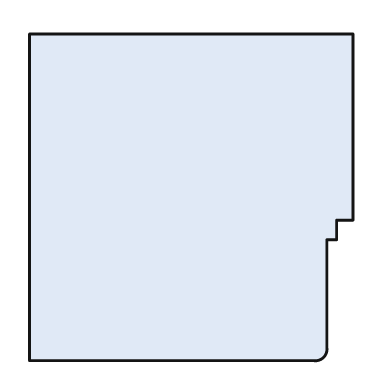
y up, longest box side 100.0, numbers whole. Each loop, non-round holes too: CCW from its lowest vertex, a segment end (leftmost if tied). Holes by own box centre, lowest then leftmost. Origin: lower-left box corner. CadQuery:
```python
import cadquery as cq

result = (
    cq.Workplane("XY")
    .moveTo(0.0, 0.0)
    .lineTo(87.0, 0.0)
    .threePointArc((90.0, 1.0), (91.0, 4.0))
    .lineTo(91.0, 37.0)
    .lineTo(94.0, 37.0)
    .lineTo(94.0, 43.0)
    .lineTo(99.0, 43.0)
    .lineTo(99.0, 100.0)
    .lineTo(0.0, 100.0)
    .close()
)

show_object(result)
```